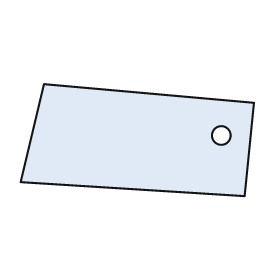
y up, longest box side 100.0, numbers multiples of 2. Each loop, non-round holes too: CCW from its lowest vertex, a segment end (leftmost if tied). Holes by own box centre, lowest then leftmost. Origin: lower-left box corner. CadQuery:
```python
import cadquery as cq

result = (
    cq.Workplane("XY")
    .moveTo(96.0, 0.0)
    .lineTo(100.0, 40.0)
    .lineTo(10.0, 48.0)
    .lineTo(0.0, 6.0)
    .close()
    .moveTo(86.0, 26.0)
    .circle(4.0)
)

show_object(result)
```